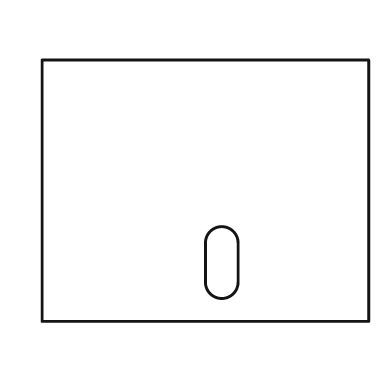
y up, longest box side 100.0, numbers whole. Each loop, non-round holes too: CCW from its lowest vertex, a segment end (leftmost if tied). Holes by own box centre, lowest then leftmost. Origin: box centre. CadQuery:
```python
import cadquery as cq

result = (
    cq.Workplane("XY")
    .moveTo(-50.0, -40.0)
    .lineTo(50.0, -40.0)
    .lineTo(50.0, 40.0)
    .lineTo(-50.0, 40.0)
    .close()
    .moveTo(0.0, -28.0)
    .threePointArc((5.0, -33.0), (10.0, -28.0))
    .lineTo(10.0, -16.0)
    .threePointArc((5.0, -11.0), (0.0, -16.0))
    .close()
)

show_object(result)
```